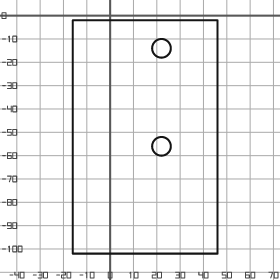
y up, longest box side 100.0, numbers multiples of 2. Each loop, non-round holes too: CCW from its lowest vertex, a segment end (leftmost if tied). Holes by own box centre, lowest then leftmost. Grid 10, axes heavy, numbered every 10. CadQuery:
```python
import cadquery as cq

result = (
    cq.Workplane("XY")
    .moveTo(-16.0, -102.0)
    .lineTo(46.0, -102.0)
    .lineTo(46.0, -2.0)
    .lineTo(-16.0, -2.0)
    .close()
    .moveTo(22.0, -56.0)
    .circle(4.0)
    .moveTo(22.0, -14.0)
    .circle(4.0)
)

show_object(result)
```